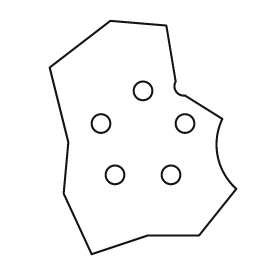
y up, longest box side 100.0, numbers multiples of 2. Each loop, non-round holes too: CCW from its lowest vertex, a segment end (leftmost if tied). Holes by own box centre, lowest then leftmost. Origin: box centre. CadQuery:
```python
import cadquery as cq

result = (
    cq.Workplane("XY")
    .moveTo(-22.0, -50.0)
    .lineTo(2.0, -42.0)
    .lineTo(24.0, -42.0)
    .lineTo(40.0, -22.0)
    .threePointArc((32.0, -8.0), (34.0, 8.0))
    .lineTo(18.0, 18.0)
    .threePointArc((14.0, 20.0), (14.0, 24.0))
    .lineTo(10.0, 48.0)
    .lineTo(-14.0, 50.0)
    .lineTo(-40.0, 30.0)
    .lineTo(-32.0, -2.0)
    .lineTo(-34.0, -24.0)
    .close()
    .moveTo(-12.0, -16.0)
    .circle(4.0)
    .moveTo(12.0, -16.0)
    .circle(4.0)
    .moveTo(-18.0, 6.0)
    .circle(4.0)
    .moveTo(18.0, 6.0)
    .circle(4.0)
    .moveTo(0.0, 20.0)
    .circle(4.0)
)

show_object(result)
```